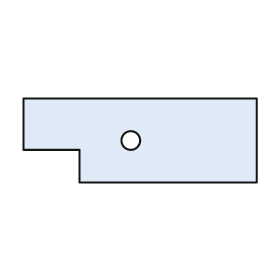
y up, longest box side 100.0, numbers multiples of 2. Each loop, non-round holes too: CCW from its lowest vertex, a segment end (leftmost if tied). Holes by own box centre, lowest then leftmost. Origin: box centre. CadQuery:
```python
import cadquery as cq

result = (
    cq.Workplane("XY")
    .moveTo(-26.0, -18.0)
    .lineTo(50.0, -18.0)
    .lineTo(50.0, 18.0)
    .lineTo(-50.0, 18.0)
    .lineTo(-50.0, -4.0)
    .lineTo(-26.0, -4.0)
    .close()
    .moveTo(-4.0, 0.0)
    .circle(4.0)
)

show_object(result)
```